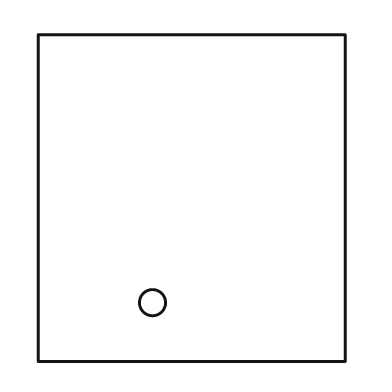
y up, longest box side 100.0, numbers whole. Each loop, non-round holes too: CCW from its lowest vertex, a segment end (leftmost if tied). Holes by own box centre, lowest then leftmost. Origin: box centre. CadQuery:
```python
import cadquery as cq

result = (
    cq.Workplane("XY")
    .moveTo(-47.0, -50.0)
    .lineTo(47.0, -50.0)
    .lineTo(47.0, 50.0)
    .lineTo(-47.0, 50.0)
    .close()
    .moveTo(-12.0, -32.0)
    .circle(4.0)
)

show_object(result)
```